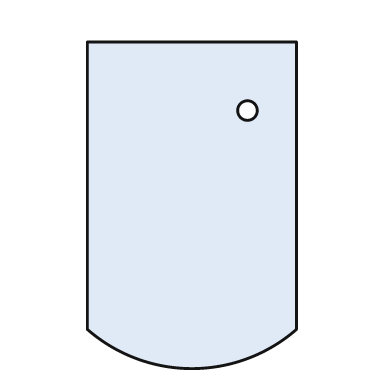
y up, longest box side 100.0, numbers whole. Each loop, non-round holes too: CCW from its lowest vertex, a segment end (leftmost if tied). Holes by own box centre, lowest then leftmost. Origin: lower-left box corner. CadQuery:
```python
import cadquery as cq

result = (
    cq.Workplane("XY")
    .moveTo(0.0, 12.0)
    .threePointArc((32.0, 0.0), (64.0, 12.0))
    .lineTo(64.0, 100.0)
    .lineTo(0.0, 100.0)
    .close()
    .moveTo(49.0, 79.0)
    .circle(3.0)
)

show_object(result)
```